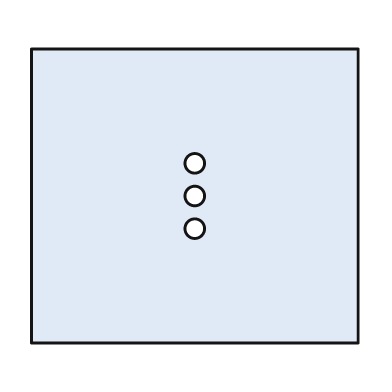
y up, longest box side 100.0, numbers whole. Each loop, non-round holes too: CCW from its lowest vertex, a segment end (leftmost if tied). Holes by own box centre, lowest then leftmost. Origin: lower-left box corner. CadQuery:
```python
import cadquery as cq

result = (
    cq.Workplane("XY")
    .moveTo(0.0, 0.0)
    .lineTo(100.0, 0.0)
    .lineTo(100.0, 90.0)
    .lineTo(0.0, 90.0)
    .close()
    .moveTo(50.0, 35.0)
    .circle(3.0)
    .moveTo(50.0, 45.0)
    .circle(3.0)
    .moveTo(50.0, 55.0)
    .circle(3.0)
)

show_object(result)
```